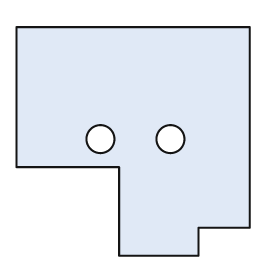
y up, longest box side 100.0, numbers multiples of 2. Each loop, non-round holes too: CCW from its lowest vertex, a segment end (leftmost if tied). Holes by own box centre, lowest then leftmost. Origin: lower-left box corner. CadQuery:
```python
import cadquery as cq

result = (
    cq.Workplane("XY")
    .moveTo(44.0, 0.0)
    .lineTo(78.0, 0.0)
    .lineTo(78.0, 12.0)
    .lineTo(100.0, 12.0)
    .lineTo(100.0, 98.0)
    .lineTo(0.0, 98.0)
    .lineTo(0.0, 38.0)
    .lineTo(44.0, 38.0)
    .close()
    .moveTo(36.0, 50.0)
    .circle(6.0)
    .moveTo(66.0, 50.0)
    .circle(6.0)
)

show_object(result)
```